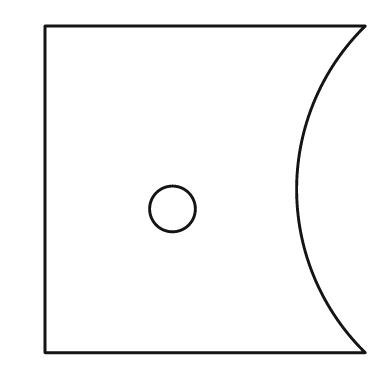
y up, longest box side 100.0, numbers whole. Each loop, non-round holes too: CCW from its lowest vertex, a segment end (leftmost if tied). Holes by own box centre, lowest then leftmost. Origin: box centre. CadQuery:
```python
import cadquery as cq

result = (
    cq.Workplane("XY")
    .moveTo(-49.0, -50.0)
    .lineTo(49.0, -50.0)
    .threePointArc((28.0, 0.0), (49.0, 50.0))
    .lineTo(-49.0, 50.0)
    .close()
    .moveTo(-10.0, -6.0)
    .circle(7.0)
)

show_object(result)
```